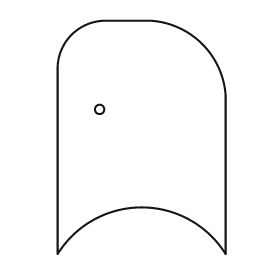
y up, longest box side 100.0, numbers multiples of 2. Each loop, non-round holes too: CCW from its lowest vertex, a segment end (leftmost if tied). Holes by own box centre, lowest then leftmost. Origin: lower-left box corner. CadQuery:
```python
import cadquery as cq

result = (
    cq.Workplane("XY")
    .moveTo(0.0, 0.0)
    .threePointArc((36.0, 20.0), (72.0, 0.0))
    .lineTo(72.0, 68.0)
    .threePointArc((62.0, 90.0), (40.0, 100.0))
    .lineTo(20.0, 100.0)
    .threePointArc((6.0, 94.0), (0.0, 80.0))
    .close()
    .moveTo(18.0, 62.0)
    .circle(2.0)
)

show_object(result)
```